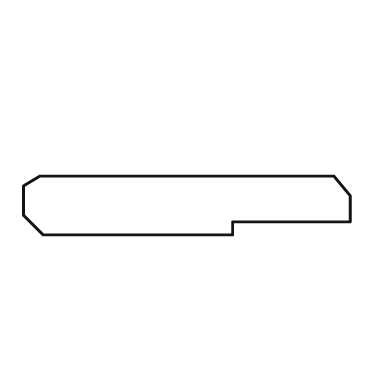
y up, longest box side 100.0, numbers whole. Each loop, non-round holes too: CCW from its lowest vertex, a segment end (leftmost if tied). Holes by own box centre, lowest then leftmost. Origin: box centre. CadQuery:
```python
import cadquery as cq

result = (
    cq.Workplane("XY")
    .moveTo(-44.0, -9.0)
    .lineTo(14.0, -9.0)
    .lineTo(14.0, -5.0)
    .lineTo(50.0, -5.0)
    .lineTo(50.0, 3.0)
    .lineTo(45.0, 9.0)
    .lineTo(-45.0, 9.0)
    .lineTo(-50.0, 6.0)
    .lineTo(-50.0, -3.0)
    .close()
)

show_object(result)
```